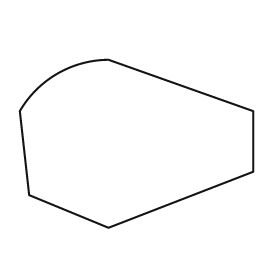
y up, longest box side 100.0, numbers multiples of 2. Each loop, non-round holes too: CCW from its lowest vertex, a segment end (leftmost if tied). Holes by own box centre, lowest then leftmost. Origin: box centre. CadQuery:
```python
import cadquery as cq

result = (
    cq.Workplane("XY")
    .moveTo(-12.0, -36.0)
    .lineTo(50.0, -12.0)
    .lineTo(50.0, 14.0)
    .lineTo(-12.0, 36.0)
    .threePointArc((-34.0, 30.0), (-50.0, 14.0))
    .lineTo(-46.0, -22.0)
    .close()
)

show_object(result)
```